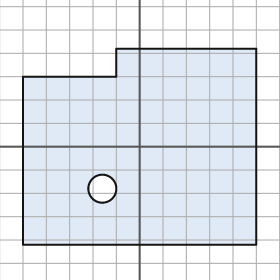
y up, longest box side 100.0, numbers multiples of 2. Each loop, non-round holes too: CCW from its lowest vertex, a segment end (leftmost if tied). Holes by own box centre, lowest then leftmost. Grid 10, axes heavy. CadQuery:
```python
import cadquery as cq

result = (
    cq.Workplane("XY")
    .moveTo(-50.0, -42.0)
    .lineTo(50.0, -42.0)
    .lineTo(50.0, 42.0)
    .lineTo(-10.0, 42.0)
    .lineTo(-10.0, 30.0)
    .lineTo(-50.0, 30.0)
    .close()
    .moveTo(-16.0, -18.0)
    .circle(6.0)
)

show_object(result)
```